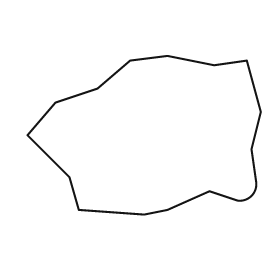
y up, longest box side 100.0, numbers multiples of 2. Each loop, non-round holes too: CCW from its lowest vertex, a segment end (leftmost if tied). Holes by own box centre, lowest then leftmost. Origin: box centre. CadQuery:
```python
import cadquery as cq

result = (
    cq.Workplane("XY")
    .moveTo(0.0, -34.0)
    .lineTo(10.0, -32.0)
    .lineTo(28.0, -24.0)
    .lineTo(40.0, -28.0)
    .threePointArc((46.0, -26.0), (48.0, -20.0))
    .lineTo(46.0, -6.0)
    .lineTo(50.0, 10.0)
    .lineTo(44.0, 32.0)
    .lineTo(30.0, 30.0)
    .lineTo(10.0, 34.0)
    .lineTo(-6.0, 32.0)
    .lineTo(-20.0, 20.0)
    .lineTo(-38.0, 14.0)
    .lineTo(-50.0, 0.0)
    .lineTo(-32.0, -18.0)
    .lineTo(-28.0, -32.0)
    .close()
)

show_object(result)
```